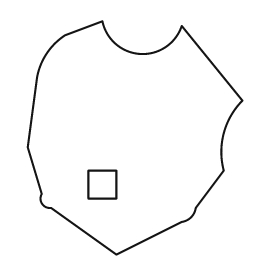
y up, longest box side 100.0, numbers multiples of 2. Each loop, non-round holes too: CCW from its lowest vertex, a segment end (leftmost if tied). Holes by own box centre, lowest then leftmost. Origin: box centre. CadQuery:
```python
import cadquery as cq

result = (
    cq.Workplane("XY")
    .moveTo(-8.0, -50.0)
    .lineTo(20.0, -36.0)
    .threePointArc((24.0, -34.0), (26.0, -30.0))
    .lineTo(38.0, -14.0)
    .threePointArc((38.0, 2.0), (46.0, 16.0))
    .lineTo(20.0, 48.0)
    .threePointArc((2.0, 36.0), (-14.0, 50.0))
    .lineTo(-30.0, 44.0)
    .threePointArc((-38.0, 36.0), (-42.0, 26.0))
    .lineTo(-46.0, -4.0)
    .lineTo(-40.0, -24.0)
    .threePointArc((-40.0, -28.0), (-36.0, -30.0))
    .close()
    .moveTo(-20.0, -26.0)
    .lineTo(-8.0, -26.0)
    .lineTo(-8.0, -14.0)
    .lineTo(-20.0, -14.0)
    .close()
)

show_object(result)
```